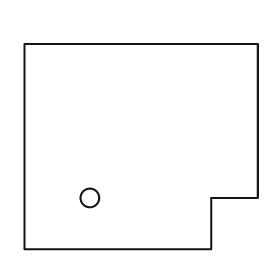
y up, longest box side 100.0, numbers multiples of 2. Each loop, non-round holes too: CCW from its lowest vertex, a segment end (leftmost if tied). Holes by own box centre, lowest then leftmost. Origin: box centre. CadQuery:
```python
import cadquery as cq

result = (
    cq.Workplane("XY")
    .moveTo(-50.0, -44.0)
    .lineTo(30.0, -44.0)
    .lineTo(30.0, -22.0)
    .lineTo(50.0, -22.0)
    .lineTo(50.0, 44.0)
    .lineTo(-50.0, 44.0)
    .close()
    .moveTo(-22.0, -22.0)
    .circle(4.0)
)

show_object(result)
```